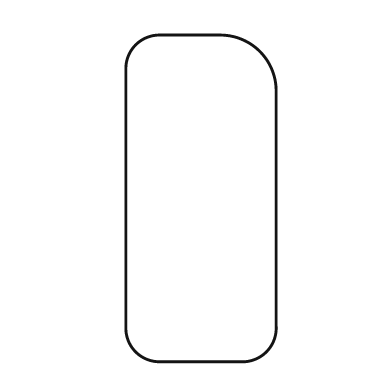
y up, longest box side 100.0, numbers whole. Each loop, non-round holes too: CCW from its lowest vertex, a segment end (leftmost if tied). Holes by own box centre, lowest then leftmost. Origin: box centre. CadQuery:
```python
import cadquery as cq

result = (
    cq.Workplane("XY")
    .moveTo(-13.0, -50.0)
    .lineTo(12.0, -50.0)
    .threePointArc((20.0, -47.0), (23.0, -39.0))
    .lineTo(23.0, 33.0)
    .threePointArc((18.0, 45.0), (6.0, 50.0))
    .lineTo(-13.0, 50.0)
    .threePointArc((-20.0, 47.0), (-23.0, 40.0))
    .lineTo(-23.0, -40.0)
    .threePointArc((-20.0, -47.0), (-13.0, -50.0))
    .close()
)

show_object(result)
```